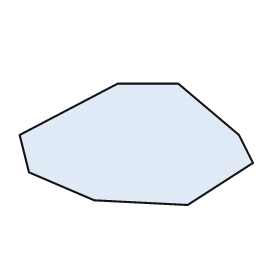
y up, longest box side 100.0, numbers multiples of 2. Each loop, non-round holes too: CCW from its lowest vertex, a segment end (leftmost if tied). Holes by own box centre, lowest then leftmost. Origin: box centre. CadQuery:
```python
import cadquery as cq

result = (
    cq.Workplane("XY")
    .moveTo(22.0, -26.0)
    .lineTo(50.0, -8.0)
    .lineTo(44.0, 4.0)
    .lineTo(18.0, 26.0)
    .lineTo(-8.0, 26.0)
    .lineTo(-50.0, 4.0)
    .lineTo(-46.0, -12.0)
    .lineTo(-18.0, -24.0)
    .close()
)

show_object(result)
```